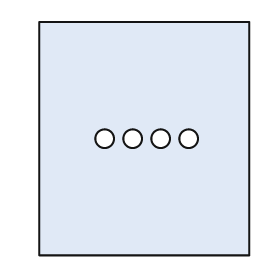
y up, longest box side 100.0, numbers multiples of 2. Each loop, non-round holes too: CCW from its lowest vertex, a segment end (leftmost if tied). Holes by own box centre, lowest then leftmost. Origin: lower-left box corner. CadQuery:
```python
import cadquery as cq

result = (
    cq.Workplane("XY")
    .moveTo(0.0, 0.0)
    .lineTo(90.0, 0.0)
    .lineTo(90.0, 100.0)
    .lineTo(0.0, 100.0)
    .close()
    .moveTo(28.0, 50.0)
    .circle(4.0)
    .moveTo(40.0, 50.0)
    .circle(4.0)
    .moveTo(52.0, 50.0)
    .circle(4.0)
    .moveTo(64.0, 50.0)
    .circle(4.0)
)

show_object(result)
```